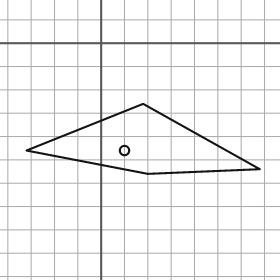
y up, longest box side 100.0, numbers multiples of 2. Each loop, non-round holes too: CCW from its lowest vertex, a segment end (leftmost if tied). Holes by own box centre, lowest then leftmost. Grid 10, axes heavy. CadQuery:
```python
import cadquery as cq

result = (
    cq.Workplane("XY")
    .moveTo(20.0, -56.0)
    .lineTo(68.0, -54.0)
    .lineTo(18.0, -26.0)
    .lineTo(-32.0, -46.0)
    .close()
    .moveTo(10.0, -46.0)
    .circle(2.0)
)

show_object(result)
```